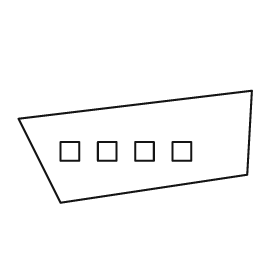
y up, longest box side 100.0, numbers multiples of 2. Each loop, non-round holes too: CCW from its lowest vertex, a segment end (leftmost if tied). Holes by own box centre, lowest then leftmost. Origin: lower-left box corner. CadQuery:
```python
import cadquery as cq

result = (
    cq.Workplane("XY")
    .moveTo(18.0, 0.0)
    .lineTo(98.0, 12.0)
    .lineTo(100.0, 48.0)
    .lineTo(0.0, 36.0)
    .close()
    .moveTo(18.0, 18.0)
    .lineTo(26.0, 18.0)
    .lineTo(26.0, 26.0)
    .lineTo(18.0, 26.0)
    .close()
    .moveTo(34.0, 18.0)
    .lineTo(42.0, 18.0)
    .lineTo(42.0, 26.0)
    .lineTo(34.0, 26.0)
    .close()
    .moveTo(50.0, 18.0)
    .lineTo(58.0, 18.0)
    .lineTo(58.0, 26.0)
    .lineTo(50.0, 26.0)
    .close()
    .moveTo(66.0, 18.0)
    .lineTo(74.0, 18.0)
    .lineTo(74.0, 26.0)
    .lineTo(66.0, 26.0)
    .close()
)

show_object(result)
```